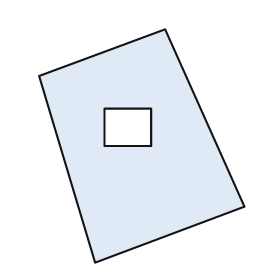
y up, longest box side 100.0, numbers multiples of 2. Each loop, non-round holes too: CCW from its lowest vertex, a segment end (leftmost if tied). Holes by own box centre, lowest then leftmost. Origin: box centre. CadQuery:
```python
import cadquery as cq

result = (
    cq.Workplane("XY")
    .moveTo(-20.0, -50.0)
    .lineTo(44.0, -26.0)
    .lineTo(10.0, 50.0)
    .lineTo(-44.0, 30.0)
    .close()
    .moveTo(-16.0, 0.0)
    .lineTo(4.0, 0.0)
    .lineTo(4.0, 16.0)
    .lineTo(-16.0, 16.0)
    .close()
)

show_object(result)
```